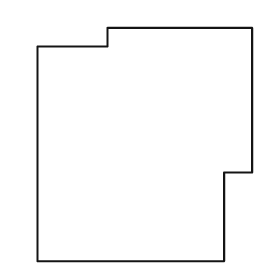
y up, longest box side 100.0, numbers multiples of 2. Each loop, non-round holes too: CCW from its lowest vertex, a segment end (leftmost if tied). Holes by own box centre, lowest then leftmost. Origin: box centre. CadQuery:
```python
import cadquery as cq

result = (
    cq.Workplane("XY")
    .moveTo(-46.0, -50.0)
    .lineTo(34.0, -50.0)
    .lineTo(34.0, -12.0)
    .lineTo(46.0, -12.0)
    .lineTo(46.0, 50.0)
    .lineTo(-16.0, 50.0)
    .lineTo(-16.0, 42.0)
    .lineTo(-46.0, 42.0)
    .close()
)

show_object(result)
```